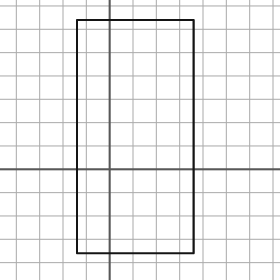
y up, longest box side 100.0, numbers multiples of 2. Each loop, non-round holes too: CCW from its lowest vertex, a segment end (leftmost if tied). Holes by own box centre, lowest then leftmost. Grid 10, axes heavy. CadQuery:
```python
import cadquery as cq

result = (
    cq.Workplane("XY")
    .moveTo(-14.0, -36.0)
    .lineTo(36.0, -36.0)
    .lineTo(36.0, 64.0)
    .lineTo(-14.0, 64.0)
    .close()
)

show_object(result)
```